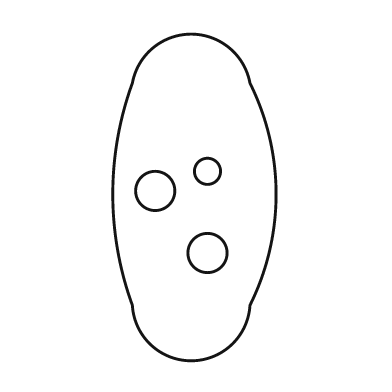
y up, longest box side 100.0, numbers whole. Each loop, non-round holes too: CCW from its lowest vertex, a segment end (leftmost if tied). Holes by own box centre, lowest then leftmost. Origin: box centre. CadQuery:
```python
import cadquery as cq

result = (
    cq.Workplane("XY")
    .moveTo(-19.0, -33.0)
    .threePointArc((-1.0, -50.0), (17.0, -33.0))
    .threePointArc((25.0, 1.0), (17.0, 35.0))
    .threePointArc((-1.0, 50.0), (-19.0, 35.0))
    .threePointArc((-25.0, 1.0), (-19.0, -33.0))
    .close()
    .moveTo(4.0, -17.0)
    .circle(6.0)
    .moveTo(-12.0, 2.0)
    .circle(6.0)
    .moveTo(4.0, 8.0)
    .circle(4.0)
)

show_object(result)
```